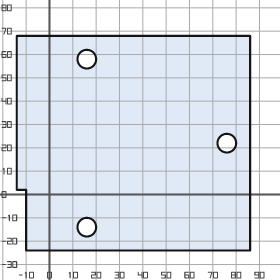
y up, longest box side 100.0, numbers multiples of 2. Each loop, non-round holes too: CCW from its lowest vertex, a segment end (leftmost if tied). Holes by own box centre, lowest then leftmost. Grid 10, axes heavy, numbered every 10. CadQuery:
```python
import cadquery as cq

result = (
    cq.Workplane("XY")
    .moveTo(-10.0, -24.0)
    .lineTo(86.0, -24.0)
    .lineTo(86.0, 68.0)
    .lineTo(-14.0, 68.0)
    .lineTo(-14.0, 2.0)
    .lineTo(-10.0, 2.0)
    .close()
    .moveTo(16.0, -14.0)
    .circle(4.0)
    .moveTo(76.0, 22.0)
    .circle(4.0)
    .moveTo(16.0, 58.0)
    .circle(4.0)
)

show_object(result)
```